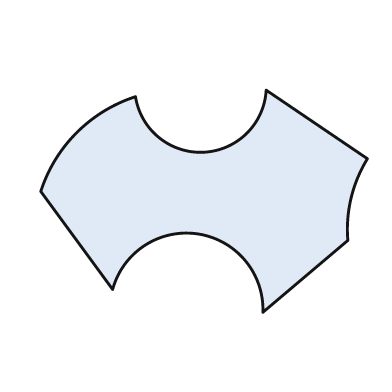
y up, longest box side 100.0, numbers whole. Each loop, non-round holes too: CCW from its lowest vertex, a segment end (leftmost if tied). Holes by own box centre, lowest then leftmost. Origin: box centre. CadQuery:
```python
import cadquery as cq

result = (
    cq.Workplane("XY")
    .moveTo(18.0, -34.0)
    .lineTo(44.0, -12.0)
    .threePointArc((45.0, 1.0), (50.0, 13.0))
    .lineTo(19.0, 34.0)
    .threePointArc((0.0, 15.0), (-21.0, 32.0))
    .threePointArc((-39.0, 21.0), (-50.0, 3.0))
    .lineTo(-28.0, -27.0)
    .threePointArc((-2.0, -10.0), (18.0, -34.0))
    .close()
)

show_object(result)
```